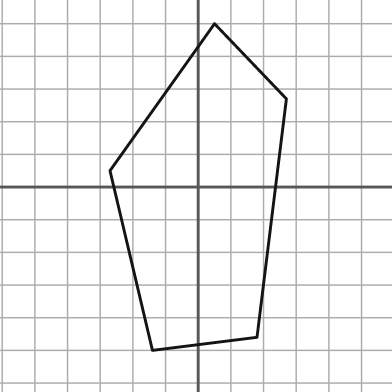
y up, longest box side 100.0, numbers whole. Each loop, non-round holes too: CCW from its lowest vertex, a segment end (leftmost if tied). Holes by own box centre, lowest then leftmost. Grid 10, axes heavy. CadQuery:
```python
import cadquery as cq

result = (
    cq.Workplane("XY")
    .moveTo(-14.0, -50.0)
    .lineTo(18.0, -46.0)
    .lineTo(27.0, 27.0)
    .lineTo(5.0, 50.0)
    .lineTo(-27.0, 5.0)
    .close()
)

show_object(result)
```